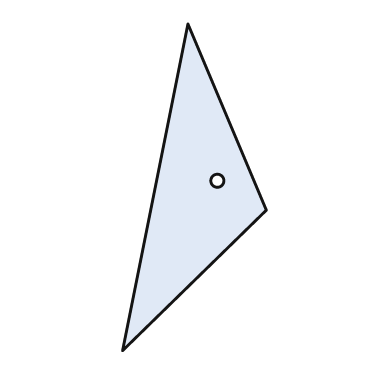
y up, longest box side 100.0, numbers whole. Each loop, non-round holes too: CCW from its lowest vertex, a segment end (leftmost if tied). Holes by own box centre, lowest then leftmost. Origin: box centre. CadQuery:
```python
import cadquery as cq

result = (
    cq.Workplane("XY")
    .moveTo(-22.0, -50.0)
    .lineTo(22.0, -7.0)
    .lineTo(-2.0, 50.0)
    .close()
    .moveTo(7.0, 2.0)
    .circle(2.0)
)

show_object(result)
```